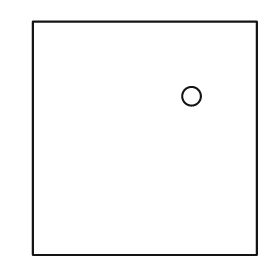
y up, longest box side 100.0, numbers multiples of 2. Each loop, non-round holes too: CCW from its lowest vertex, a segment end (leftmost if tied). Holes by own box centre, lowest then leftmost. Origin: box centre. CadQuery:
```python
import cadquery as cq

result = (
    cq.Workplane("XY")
    .moveTo(-48.0, -50.0)
    .lineTo(48.0, -50.0)
    .lineTo(48.0, 50.0)
    .lineTo(-48.0, 50.0)
    .close()
    .moveTo(20.0, 18.0)
    .circle(4.0)
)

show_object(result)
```